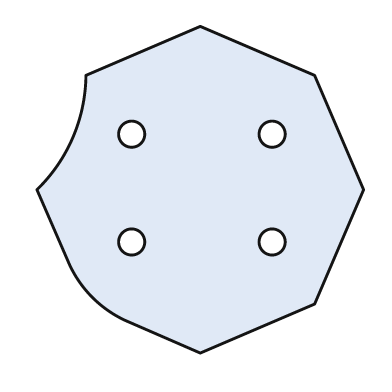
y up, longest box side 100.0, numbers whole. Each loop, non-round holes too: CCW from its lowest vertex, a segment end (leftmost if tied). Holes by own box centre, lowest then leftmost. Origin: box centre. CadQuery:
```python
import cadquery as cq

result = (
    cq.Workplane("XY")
    .moveTo(0.0, -50.0)
    .lineTo(35.0, -35.0)
    .lineTo(50.0, 0.0)
    .lineTo(35.0, 35.0)
    .lineTo(0.0, 50.0)
    .lineTo(-35.0, 35.0)
    .threePointArc((-39.0, 16.0), (-50.0, 0.0))
    .lineTo(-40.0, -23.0)
    .threePointArc((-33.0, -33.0), (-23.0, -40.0))
    .close()
    .moveTo(-21.0, -16.0)
    .circle(4.0)
    .moveTo(22.0, -16.0)
    .circle(4.0)
    .moveTo(-21.0, 17.0)
    .circle(4.0)
    .moveTo(22.0, 17.0)
    .circle(4.0)
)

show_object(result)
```